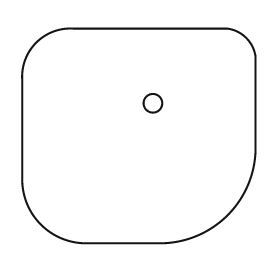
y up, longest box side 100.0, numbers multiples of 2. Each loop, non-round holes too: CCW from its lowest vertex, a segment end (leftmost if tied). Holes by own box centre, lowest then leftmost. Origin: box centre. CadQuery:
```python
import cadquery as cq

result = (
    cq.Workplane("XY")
    .moveTo(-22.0, -46.0)
    .lineTo(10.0, -46.0)
    .threePointArc((38.0, -34.0), (50.0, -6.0))
    .lineTo(50.0, 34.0)
    .threePointArc((46.0, 42.0), (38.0, 46.0))
    .lineTo(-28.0, 46.0)
    .threePointArc((-44.0, 40.0), (-50.0, 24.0))
    .lineTo(-50.0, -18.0)
    .threePointArc((-42.0, -38.0), (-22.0, -46.0))
    .close()
    .moveTo(6.0, 14.0)
    .circle(4.0)
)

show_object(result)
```